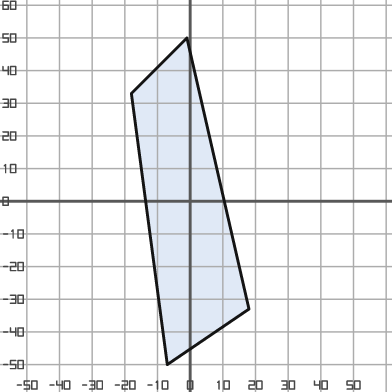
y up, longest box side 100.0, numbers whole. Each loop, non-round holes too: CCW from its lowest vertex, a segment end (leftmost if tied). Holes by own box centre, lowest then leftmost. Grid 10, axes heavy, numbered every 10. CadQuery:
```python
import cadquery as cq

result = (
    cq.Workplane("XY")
    .moveTo(-7.0, -50.0)
    .lineTo(18.0, -33.0)
    .lineTo(-1.0, 50.0)
    .lineTo(-18.0, 33.0)
    .close()
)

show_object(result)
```